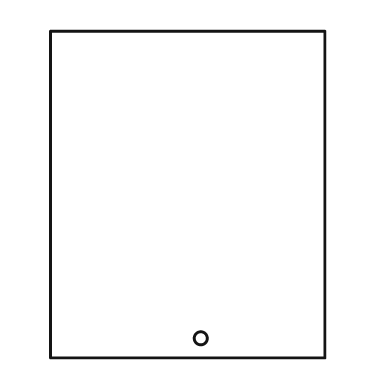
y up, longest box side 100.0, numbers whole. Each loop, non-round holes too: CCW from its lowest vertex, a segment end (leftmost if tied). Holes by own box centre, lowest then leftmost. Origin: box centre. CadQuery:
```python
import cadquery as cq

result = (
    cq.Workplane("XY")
    .moveTo(-42.0, -50.0)
    .lineTo(42.0, -50.0)
    .lineTo(42.0, 50.0)
    .lineTo(-42.0, 50.0)
    .close()
    .moveTo(4.0, -44.0)
    .circle(2.0)
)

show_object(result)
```